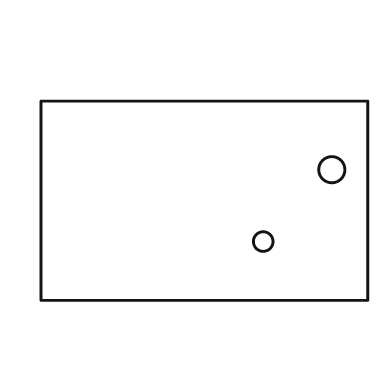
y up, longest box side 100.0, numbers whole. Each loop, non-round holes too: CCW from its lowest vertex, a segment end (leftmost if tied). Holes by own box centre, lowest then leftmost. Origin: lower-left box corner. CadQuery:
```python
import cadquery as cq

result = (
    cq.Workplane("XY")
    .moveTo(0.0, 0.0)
    .lineTo(100.0, 0.0)
    .lineTo(100.0, 61.0)
    .lineTo(0.0, 61.0)
    .close()
    .moveTo(68.0, 18.0)
    .circle(3.0)
    .moveTo(89.0, 40.0)
    .circle(4.0)
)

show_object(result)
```